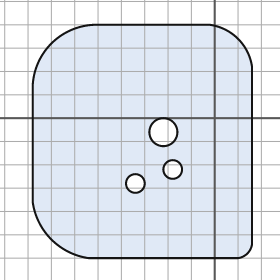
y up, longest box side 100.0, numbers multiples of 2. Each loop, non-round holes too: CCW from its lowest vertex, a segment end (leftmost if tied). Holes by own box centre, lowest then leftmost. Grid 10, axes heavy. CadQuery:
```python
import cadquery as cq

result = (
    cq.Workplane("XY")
    .moveTo(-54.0, -60.0)
    .lineTo(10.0, -60.0)
    .threePointArc((14.0, -58.0), (16.0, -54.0))
    .lineTo(16.0, 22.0)
    .threePointArc((10.0, 34.0), (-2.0, 40.0))
    .lineTo(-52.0, 40.0)
    .threePointArc((-70.0, 32.0), (-78.0, 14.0))
    .lineTo(-78.0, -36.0)
    .threePointArc((-70.0, -52.0), (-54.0, -60.0))
    .close()
    .moveTo(-34.0, -28.0)
    .circle(4.0)
    .moveTo(-18.0, -22.0)
    .circle(4.0)
    .moveTo(-22.0, -6.0)
    .circle(6.0)
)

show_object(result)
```